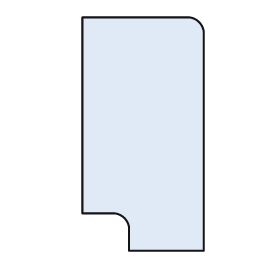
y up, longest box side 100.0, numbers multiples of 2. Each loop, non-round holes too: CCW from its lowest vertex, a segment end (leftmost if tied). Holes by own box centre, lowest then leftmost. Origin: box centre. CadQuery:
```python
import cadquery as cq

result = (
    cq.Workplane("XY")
    .moveTo(-6.0, -50.0)
    .lineTo(26.0, -50.0)
    .lineTo(26.0, 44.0)
    .threePointArc((24.0, 48.0), (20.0, 50.0))
    .lineTo(-26.0, 50.0)
    .lineTo(-26.0, -34.0)
    .lineTo(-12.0, -34.0)
    .threePointArc((-8.0, -36.0), (-6.0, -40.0))
    .close()
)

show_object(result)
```